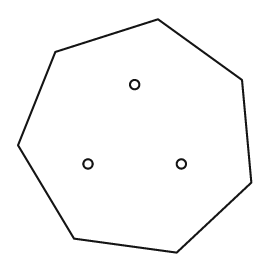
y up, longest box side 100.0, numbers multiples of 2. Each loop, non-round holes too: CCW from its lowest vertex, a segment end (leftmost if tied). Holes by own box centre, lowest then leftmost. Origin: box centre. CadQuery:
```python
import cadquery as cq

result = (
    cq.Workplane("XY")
    .moveTo(18.0, -50.0)
    .lineTo(50.0, -20.0)
    .lineTo(46.0, 24.0)
    .lineTo(10.0, 50.0)
    .lineTo(-34.0, 36.0)
    .lineTo(-50.0, -4.0)
    .lineTo(-26.0, -44.0)
    .close()
    .moveTo(-20.0, -12.0)
    .circle(2.0)
    .moveTo(20.0, -12.0)
    .circle(2.0)
    .moveTo(0.0, 22.0)
    .circle(2.0)
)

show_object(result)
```